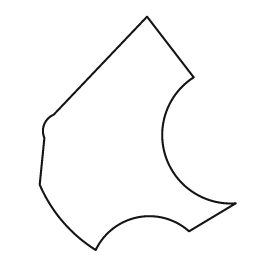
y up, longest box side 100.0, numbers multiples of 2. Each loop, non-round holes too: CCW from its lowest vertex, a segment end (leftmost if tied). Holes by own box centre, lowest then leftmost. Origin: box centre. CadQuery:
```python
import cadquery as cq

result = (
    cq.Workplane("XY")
    .moveTo(-18.0, -50.0)
    .threePointArc((0.0, -36.0), (22.0, -42.0))
    .lineTo(42.0, -30.0)
    .threePointArc((12.0, -10.0), (24.0, 24.0))
    .lineTo(4.0, 50.0)
    .lineTo(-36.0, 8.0)
    .threePointArc((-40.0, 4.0), (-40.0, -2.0))
    .lineTo(-42.0, -22.0)
    .threePointArc((-32.0, -38.0), (-18.0, -50.0))
    .close()
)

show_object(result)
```